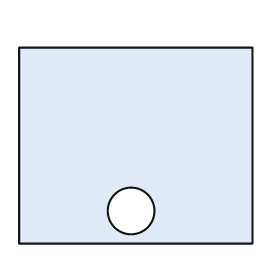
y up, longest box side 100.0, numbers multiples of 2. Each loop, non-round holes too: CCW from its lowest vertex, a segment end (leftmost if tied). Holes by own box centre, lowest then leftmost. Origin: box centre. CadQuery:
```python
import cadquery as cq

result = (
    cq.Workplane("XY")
    .moveTo(-50.0, -42.0)
    .lineTo(50.0, -42.0)
    .lineTo(50.0, 42.0)
    .lineTo(-50.0, 42.0)
    .close()
    .moveTo(-2.0, -28.0)
    .circle(10.0)
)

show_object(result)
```